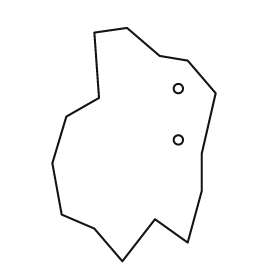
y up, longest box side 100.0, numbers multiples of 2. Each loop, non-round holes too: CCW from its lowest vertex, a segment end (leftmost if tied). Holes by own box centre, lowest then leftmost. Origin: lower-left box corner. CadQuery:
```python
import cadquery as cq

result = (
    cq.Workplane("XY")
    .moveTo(30.0, 0.0)
    .lineTo(44.0, 18.0)
    .lineTo(58.0, 8.0)
    .lineTo(64.0, 30.0)
    .lineTo(64.0, 46.0)
    .lineTo(70.0, 72.0)
    .lineTo(58.0, 86.0)
    .lineTo(46.0, 88.0)
    .lineTo(32.0, 100.0)
    .lineTo(18.0, 98.0)
    .lineTo(20.0, 70.0)
    .lineTo(6.0, 62.0)
    .lineTo(0.0, 42.0)
    .lineTo(4.0, 20.0)
    .lineTo(18.0, 14.0)
    .close()
    .moveTo(54.0, 52.0)
    .circle(2.0)
    .moveTo(54.0, 74.0)
    .circle(2.0)
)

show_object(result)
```